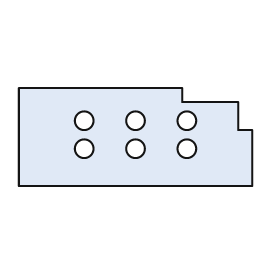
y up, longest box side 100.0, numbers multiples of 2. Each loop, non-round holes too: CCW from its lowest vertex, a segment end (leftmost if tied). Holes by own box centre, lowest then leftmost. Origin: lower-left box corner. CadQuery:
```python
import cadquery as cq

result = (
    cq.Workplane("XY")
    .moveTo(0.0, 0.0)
    .lineTo(100.0, 0.0)
    .lineTo(100.0, 24.0)
    .lineTo(94.0, 24.0)
    .lineTo(94.0, 36.0)
    .lineTo(70.0, 36.0)
    .lineTo(70.0, 42.0)
    .lineTo(0.0, 42.0)
    .close()
    .moveTo(28.0, 16.0)
    .circle(4.0)
    .moveTo(50.0, 16.0)
    .circle(4.0)
    .moveTo(72.0, 16.0)
    .circle(4.0)
    .moveTo(28.0, 28.0)
    .circle(4.0)
    .moveTo(50.0, 28.0)
    .circle(4.0)
    .moveTo(72.0, 28.0)
    .circle(4.0)
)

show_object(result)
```